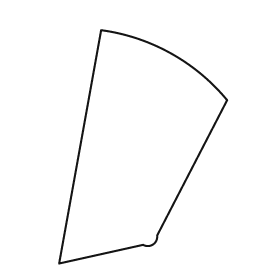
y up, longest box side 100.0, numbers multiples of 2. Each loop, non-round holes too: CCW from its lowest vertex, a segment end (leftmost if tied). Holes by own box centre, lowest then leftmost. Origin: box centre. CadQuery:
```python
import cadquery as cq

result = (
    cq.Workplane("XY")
    .moveTo(-36.0, -50.0)
    .lineTo(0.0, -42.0)
    .threePointArc((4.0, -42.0), (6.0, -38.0))
    .lineTo(36.0, 20.0)
    .threePointArc((12.0, 40.0), (-18.0, 50.0))
    .close()
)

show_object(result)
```